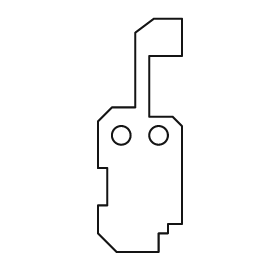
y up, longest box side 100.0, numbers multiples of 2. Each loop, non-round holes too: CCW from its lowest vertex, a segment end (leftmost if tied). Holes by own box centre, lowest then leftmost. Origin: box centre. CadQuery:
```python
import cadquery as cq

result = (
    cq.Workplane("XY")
    .moveTo(-10.0, -50.0)
    .lineTo(8.0, -50.0)
    .lineTo(8.0, -42.0)
    .lineTo(12.0, -42.0)
    .lineTo(12.0, -38.0)
    .lineTo(18.0, -38.0)
    .lineTo(18.0, 4.0)
    .lineTo(14.0, 8.0)
    .lineTo(4.0, 8.0)
    .lineTo(4.0, 34.0)
    .lineTo(18.0, 34.0)
    .lineTo(18.0, 50.0)
    .lineTo(6.0, 50.0)
    .lineTo(-2.0, 44.0)
    .lineTo(-2.0, 12.0)
    .lineTo(-12.0, 12.0)
    .lineTo(-18.0, 6.0)
    .lineTo(-18.0, -14.0)
    .lineTo(-14.0, -14.0)
    .lineTo(-14.0, -30.0)
    .lineTo(-18.0, -30.0)
    .lineTo(-18.0, -42.0)
    .close()
    .moveTo(-8.0, 0.0)
    .circle(4.0)
    .moveTo(8.0, 0.0)
    .circle(4.0)
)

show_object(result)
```